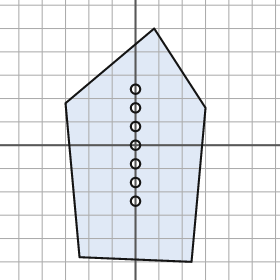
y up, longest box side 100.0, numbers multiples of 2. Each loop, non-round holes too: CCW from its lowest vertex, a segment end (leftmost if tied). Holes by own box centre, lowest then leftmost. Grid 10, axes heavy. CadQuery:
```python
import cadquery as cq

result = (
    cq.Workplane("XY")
    .moveTo(24.0, -50.0)
    .lineTo(30.0, 16.0)
    .lineTo(8.0, 50.0)
    .lineTo(-30.0, 18.0)
    .lineTo(-24.0, -48.0)
    .close()
    .moveTo(0.0, -24.0)
    .circle(2.0)
    .moveTo(0.0, -16.0)
    .circle(2.0)
    .moveTo(0.0, -8.0)
    .circle(2.0)
    .moveTo(0.0, 0.0)
    .circle(2.0)
    .moveTo(0.0, 8.0)
    .circle(2.0)
    .moveTo(0.0, 16.0)
    .circle(2.0)
    .moveTo(0.0, 24.0)
    .circle(2.0)
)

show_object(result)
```